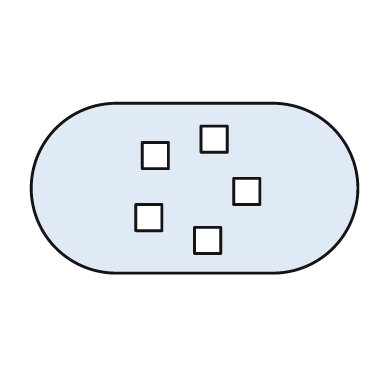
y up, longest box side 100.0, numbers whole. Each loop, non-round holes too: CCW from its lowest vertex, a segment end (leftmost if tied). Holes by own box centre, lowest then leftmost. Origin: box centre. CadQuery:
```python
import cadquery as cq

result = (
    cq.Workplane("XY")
    .moveTo(-24.0, -26.0)
    .lineTo(24.0, -26.0)
    .threePointArc((50.0, 0.0), (24.0, 26.0))
    .lineTo(-24.0, 26.0)
    .threePointArc((-50.0, 0.0), (-24.0, -26.0))
    .close()
    .moveTo(0.0, -20.0)
    .lineTo(8.0, -20.0)
    .lineTo(8.0, -12.0)
    .lineTo(0.0, -12.0)
    .close()
    .moveTo(-18.0, -13.0)
    .lineTo(-10.0, -13.0)
    .lineTo(-10.0, -5.0)
    .lineTo(-18.0, -5.0)
    .close()
    .moveTo(12.0, -5.0)
    .lineTo(20.0, -5.0)
    .lineTo(20.0, 3.0)
    .lineTo(12.0, 3.0)
    .close()
    .moveTo(-16.0, 6.0)
    .lineTo(-8.0, 6.0)
    .lineTo(-8.0, 14.0)
    .lineTo(-16.0, 14.0)
    .close()
    .moveTo(2.0, 11.0)
    .lineTo(10.0, 11.0)
    .lineTo(10.0, 19.0)
    .lineTo(2.0, 19.0)
    .close()
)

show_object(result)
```